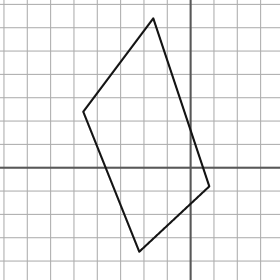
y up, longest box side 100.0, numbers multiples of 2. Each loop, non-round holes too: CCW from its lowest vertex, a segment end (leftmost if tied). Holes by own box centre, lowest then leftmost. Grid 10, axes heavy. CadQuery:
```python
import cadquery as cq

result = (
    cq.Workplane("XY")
    .moveTo(-22.0, -36.0)
    .lineTo(8.0, -8.0)
    .lineTo(-16.0, 64.0)
    .lineTo(-46.0, 24.0)
    .close()
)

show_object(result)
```